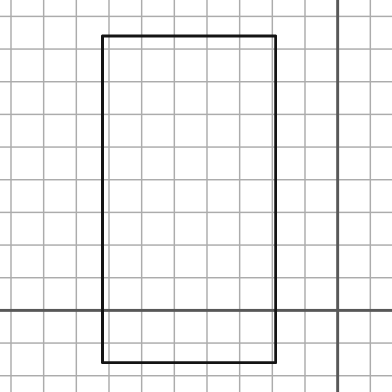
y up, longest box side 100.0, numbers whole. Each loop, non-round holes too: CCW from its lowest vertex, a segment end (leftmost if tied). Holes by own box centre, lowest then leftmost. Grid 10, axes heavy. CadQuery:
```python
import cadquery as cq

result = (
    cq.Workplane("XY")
    .moveTo(-72.0, -16.0)
    .lineTo(-19.0, -16.0)
    .lineTo(-19.0, 84.0)
    .lineTo(-72.0, 84.0)
    .close()
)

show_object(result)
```